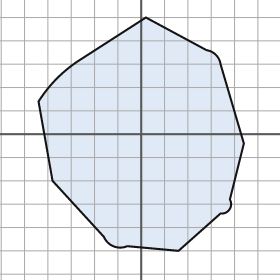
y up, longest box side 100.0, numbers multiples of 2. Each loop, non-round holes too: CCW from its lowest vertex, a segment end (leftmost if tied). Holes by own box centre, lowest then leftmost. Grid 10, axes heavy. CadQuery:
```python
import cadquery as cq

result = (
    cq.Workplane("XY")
    .moveTo(16.0, -50.0)
    .lineTo(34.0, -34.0)
    .threePointArc((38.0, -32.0), (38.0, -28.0))
    .lineTo(44.0, -4.0)
    .lineTo(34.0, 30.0)
    .threePointArc((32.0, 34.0), (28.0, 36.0))
    .lineTo(2.0, 50.0)
    .lineTo(-26.0, 32.0)
    .threePointArc((-36.0, 24.0), (-44.0, 14.0))
    .lineTo(-38.0, -20.0)
    .lineTo(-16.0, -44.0)
    .threePointArc((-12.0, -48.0), (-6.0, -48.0))
    .close()
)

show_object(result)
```